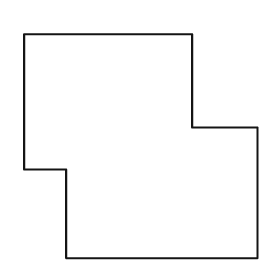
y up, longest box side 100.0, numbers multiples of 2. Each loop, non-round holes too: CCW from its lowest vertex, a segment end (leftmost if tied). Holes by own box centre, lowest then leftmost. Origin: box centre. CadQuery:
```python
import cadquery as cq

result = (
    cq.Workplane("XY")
    .moveTo(-32.0, -48.0)
    .lineTo(50.0, -48.0)
    .lineTo(50.0, 8.0)
    .lineTo(22.0, 8.0)
    .lineTo(22.0, 48.0)
    .lineTo(-50.0, 48.0)
    .lineTo(-50.0, -10.0)
    .lineTo(-32.0, -10.0)
    .close()
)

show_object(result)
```